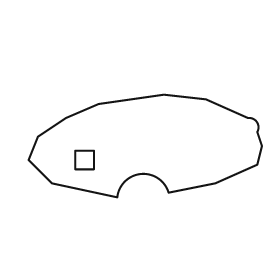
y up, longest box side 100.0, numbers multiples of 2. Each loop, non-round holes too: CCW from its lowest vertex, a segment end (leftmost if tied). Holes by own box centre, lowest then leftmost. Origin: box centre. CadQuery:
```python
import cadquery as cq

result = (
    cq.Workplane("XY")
    .moveTo(-12.0, -22.0)
    .threePointArc((-2.0, -12.0), (10.0, -20.0))
    .lineTo(30.0, -16.0)
    .lineTo(48.0, -8.0)
    .lineTo(50.0, 0.0)
    .lineTo(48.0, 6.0)
    .threePointArc((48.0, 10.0), (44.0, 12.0))
    .lineTo(26.0, 20.0)
    .lineTo(8.0, 22.0)
    .lineTo(-20.0, 18.0)
    .lineTo(-34.0, 12.0)
    .lineTo(-46.0, 4.0)
    .lineTo(-50.0, -6.0)
    .lineTo(-40.0, -16.0)
    .close()
    .moveTo(-30.0, -10.0)
    .lineTo(-22.0, -10.0)
    .lineTo(-22.0, -2.0)
    .lineTo(-30.0, -2.0)
    .close()
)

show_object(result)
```